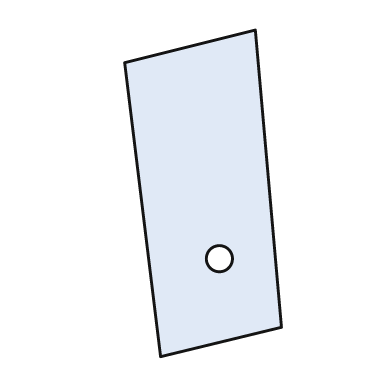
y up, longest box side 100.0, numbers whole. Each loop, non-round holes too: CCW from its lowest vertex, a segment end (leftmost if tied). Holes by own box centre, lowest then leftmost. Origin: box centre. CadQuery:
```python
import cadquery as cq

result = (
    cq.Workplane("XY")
    .moveTo(-13.0, -50.0)
    .lineTo(24.0, -41.0)
    .lineTo(16.0, 50.0)
    .lineTo(-24.0, 40.0)
    .close()
    .moveTo(5.0, -20.0)
    .circle(4.0)
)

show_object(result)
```